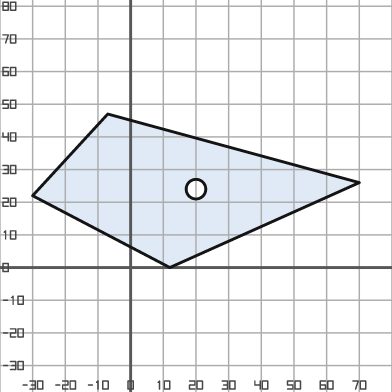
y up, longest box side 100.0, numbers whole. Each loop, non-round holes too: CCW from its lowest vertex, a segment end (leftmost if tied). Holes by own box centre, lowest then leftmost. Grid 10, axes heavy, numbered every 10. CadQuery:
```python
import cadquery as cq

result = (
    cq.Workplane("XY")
    .moveTo(12.0, 0.0)
    .lineTo(70.0, 26.0)
    .lineTo(-7.0, 47.0)
    .lineTo(-30.0, 22.0)
    .close()
    .moveTo(20.0, 24.0)
    .circle(3.0)
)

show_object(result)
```